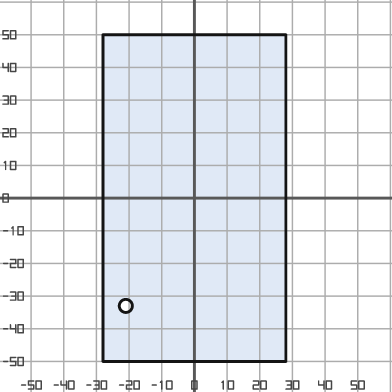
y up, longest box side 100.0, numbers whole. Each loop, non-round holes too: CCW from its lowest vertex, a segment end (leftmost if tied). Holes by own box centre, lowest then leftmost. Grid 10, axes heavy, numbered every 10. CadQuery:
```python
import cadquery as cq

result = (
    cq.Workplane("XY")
    .moveTo(-28.0, -50.0)
    .lineTo(28.0, -50.0)
    .lineTo(28.0, 50.0)
    .lineTo(-28.0, 50.0)
    .close()
    .moveTo(-21.0, -33.0)
    .circle(2.0)
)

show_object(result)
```